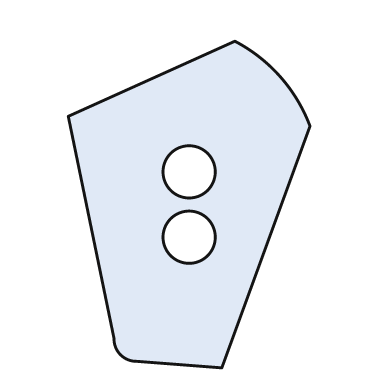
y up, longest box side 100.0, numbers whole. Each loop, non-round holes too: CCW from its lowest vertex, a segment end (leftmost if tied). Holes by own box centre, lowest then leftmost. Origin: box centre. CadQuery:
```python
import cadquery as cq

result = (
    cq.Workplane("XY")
    .moveTo(10.0, -50.0)
    .lineTo(37.0, 24.0)
    .threePointArc((28.0, 39.0), (14.0, 50.0))
    .lineTo(-37.0, 27.0)
    .lineTo(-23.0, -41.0)
    .threePointArc((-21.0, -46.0), (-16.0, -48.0))
    .close()
    .moveTo(0.0, -10.0)
    .circle(8.0)
    .moveTo(0.0, 10.0)
    .circle(8.0)
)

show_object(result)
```